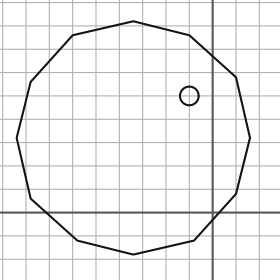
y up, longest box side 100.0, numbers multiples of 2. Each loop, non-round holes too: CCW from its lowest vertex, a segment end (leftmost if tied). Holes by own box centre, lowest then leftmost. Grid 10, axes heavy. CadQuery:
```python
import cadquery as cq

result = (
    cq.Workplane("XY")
    .moveTo(-34.0, -18.0)
    .lineTo(-8.0, -12.0)
    .lineTo(10.0, 8.0)
    .lineTo(16.0, 32.0)
    .lineTo(10.0, 58.0)
    .lineTo(-10.0, 76.0)
    .lineTo(-34.0, 82.0)
    .lineTo(-60.0, 76.0)
    .lineTo(-78.0, 56.0)
    .lineTo(-84.0, 32.0)
    .lineTo(-78.0, 6.0)
    .lineTo(-58.0, -12.0)
    .close()
    .moveTo(-10.0, 50.0)
    .circle(4.0)
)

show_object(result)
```